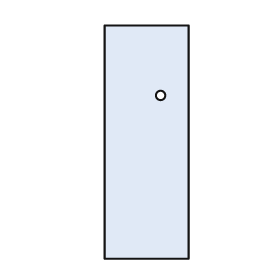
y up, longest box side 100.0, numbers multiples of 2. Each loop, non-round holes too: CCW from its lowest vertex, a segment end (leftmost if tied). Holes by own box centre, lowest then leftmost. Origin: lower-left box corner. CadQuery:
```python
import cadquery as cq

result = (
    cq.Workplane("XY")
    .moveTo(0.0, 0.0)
    .lineTo(36.0, 0.0)
    .lineTo(36.0, 100.0)
    .lineTo(0.0, 100.0)
    .close()
    .moveTo(24.0, 70.0)
    .circle(2.0)
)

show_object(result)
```